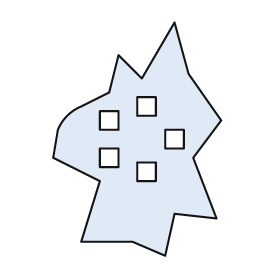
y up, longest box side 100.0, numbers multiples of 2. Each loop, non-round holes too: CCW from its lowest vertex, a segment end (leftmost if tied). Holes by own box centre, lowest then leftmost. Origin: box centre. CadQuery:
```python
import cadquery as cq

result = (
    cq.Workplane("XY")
    .moveTo(12.0, -50.0)
    .lineTo(16.0, -32.0)
    .lineTo(34.0, -34.0)
    .lineTo(24.0, -8.0)
    .lineTo(36.0, 8.0)
    .lineTo(22.0, 28.0)
    .lineTo(16.0, 50.0)
    .lineTo(2.0, 26.0)
    .lineTo(-8.0, 36.0)
    .lineTo(-12.0, 20.0)
    .lineTo(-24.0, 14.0)
    .threePointArc((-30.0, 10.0), (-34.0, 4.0))
    .lineTo(-36.0, -8.0)
    .lineTo(-16.0, -18.0)
    .lineTo(-24.0, -44.0)
    .lineTo(-2.0, -44.0)
    .close()
    .moveTo(0.0, -18.0)
    .lineTo(8.0, -18.0)
    .lineTo(8.0, -10.0)
    .lineTo(0.0, -10.0)
    .close()
    .moveTo(-16.0, -12.0)
    .lineTo(-8.0, -12.0)
    .lineTo(-8.0, -4.0)
    .lineTo(-16.0, -4.0)
    .close()
    .moveTo(12.0, -4.0)
    .lineTo(20.0, -4.0)
    .lineTo(20.0, 4.0)
    .lineTo(12.0, 4.0)
    .close()
    .moveTo(-16.0, 4.0)
    .lineTo(-8.0, 4.0)
    .lineTo(-8.0, 12.0)
    .lineTo(-16.0, 12.0)
    .close()
    .moveTo(0.0, 10.0)
    .lineTo(8.0, 10.0)
    .lineTo(8.0, 18.0)
    .lineTo(0.0, 18.0)
    .close()
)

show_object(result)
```